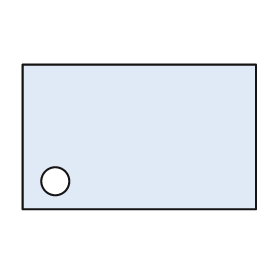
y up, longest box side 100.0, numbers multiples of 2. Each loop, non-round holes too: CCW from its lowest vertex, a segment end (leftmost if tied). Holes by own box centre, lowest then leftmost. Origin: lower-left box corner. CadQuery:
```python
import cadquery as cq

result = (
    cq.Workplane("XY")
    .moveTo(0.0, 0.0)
    .lineTo(100.0, 0.0)
    .lineTo(100.0, 62.0)
    .lineTo(0.0, 62.0)
    .close()
    .moveTo(14.0, 12.0)
    .circle(6.0)
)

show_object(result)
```